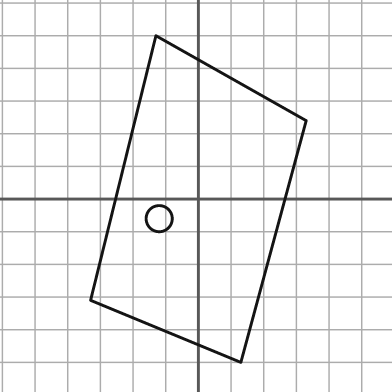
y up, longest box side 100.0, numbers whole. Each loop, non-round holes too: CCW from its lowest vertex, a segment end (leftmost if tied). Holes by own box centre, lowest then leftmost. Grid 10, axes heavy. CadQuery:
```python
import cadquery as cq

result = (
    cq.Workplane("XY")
    .moveTo(13.0, -50.0)
    .lineTo(33.0, 24.0)
    .lineTo(-13.0, 50.0)
    .lineTo(-33.0, -31.0)
    .close()
    .moveTo(-12.0, -6.0)
    .circle(4.0)
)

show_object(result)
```